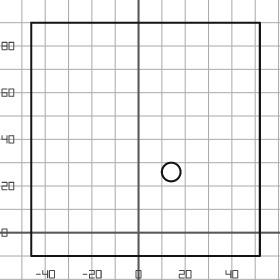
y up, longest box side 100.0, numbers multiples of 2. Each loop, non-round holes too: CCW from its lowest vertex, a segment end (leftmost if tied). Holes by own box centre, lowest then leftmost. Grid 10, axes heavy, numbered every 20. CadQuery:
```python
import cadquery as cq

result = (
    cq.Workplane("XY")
    .moveTo(-46.0, -10.0)
    .lineTo(52.0, -10.0)
    .lineTo(52.0, 90.0)
    .lineTo(-46.0, 90.0)
    .close()
    .moveTo(14.0, 26.0)
    .circle(4.0)
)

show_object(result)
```